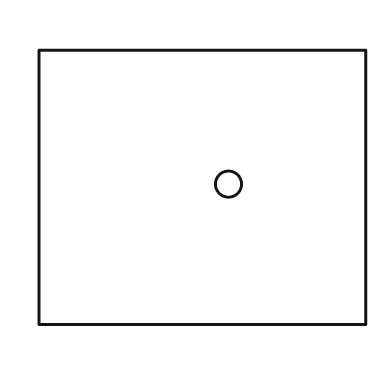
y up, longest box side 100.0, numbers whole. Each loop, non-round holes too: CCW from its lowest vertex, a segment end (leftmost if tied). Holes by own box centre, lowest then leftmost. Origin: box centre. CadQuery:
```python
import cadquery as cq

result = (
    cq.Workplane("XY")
    .moveTo(-50.0, -42.0)
    .lineTo(50.0, -42.0)
    .lineTo(50.0, 42.0)
    .lineTo(-50.0, 42.0)
    .close()
    .moveTo(8.0, 1.0)
    .circle(4.0)
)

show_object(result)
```